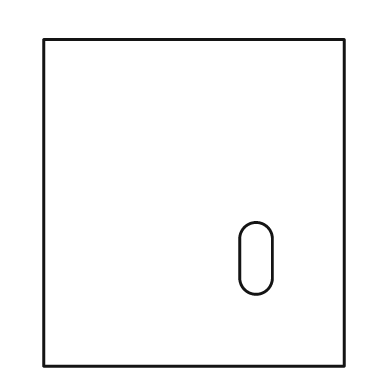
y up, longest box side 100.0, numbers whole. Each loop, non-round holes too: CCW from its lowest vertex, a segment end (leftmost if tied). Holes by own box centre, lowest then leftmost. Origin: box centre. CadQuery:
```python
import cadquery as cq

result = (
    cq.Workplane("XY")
    .moveTo(-46.0, -50.0)
    .lineTo(46.0, -50.0)
    .lineTo(46.0, 50.0)
    .lineTo(-46.0, 50.0)
    .close()
    .moveTo(14.0, -23.0)
    .threePointArc((19.0, -28.0), (24.0, -23.0))
    .lineTo(24.0, -11.0)
    .threePointArc((19.0, -6.0), (14.0, -11.0))
    .close()
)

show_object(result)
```